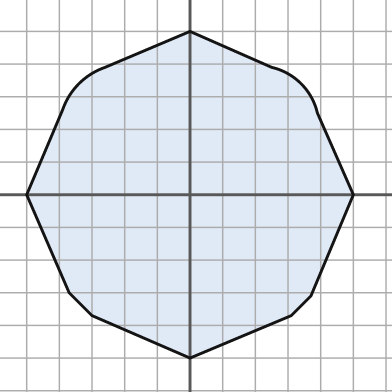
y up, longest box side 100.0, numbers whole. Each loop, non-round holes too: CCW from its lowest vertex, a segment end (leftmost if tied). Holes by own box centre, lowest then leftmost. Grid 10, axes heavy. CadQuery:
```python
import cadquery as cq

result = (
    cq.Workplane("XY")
    .moveTo(0.0, -50.0)
    .lineTo(31.0, -37.0)
    .lineTo(37.0, -31.0)
    .lineTo(50.0, 0.0)
    .lineTo(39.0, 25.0)
    .threePointArc((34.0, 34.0), (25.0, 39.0))
    .lineTo(0.0, 50.0)
    .lineTo(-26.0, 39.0)
    .threePointArc((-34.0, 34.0), (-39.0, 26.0))
    .lineTo(-50.0, 0.0)
    .lineTo(-37.0, -30.0)
    .lineTo(-30.0, -37.0)
    .close()
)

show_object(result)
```